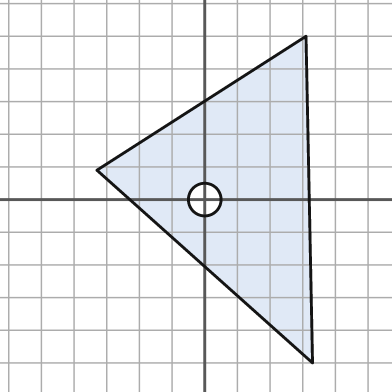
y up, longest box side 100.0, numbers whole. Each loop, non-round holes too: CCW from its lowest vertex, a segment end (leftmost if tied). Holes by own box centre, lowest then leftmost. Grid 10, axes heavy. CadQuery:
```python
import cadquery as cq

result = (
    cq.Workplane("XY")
    .moveTo(33.0, -50.0)
    .lineTo(31.0, 50.0)
    .lineTo(-33.0, 9.0)
    .close()
    .moveTo(0.0, 0.0)
    .circle(5.0)
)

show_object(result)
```